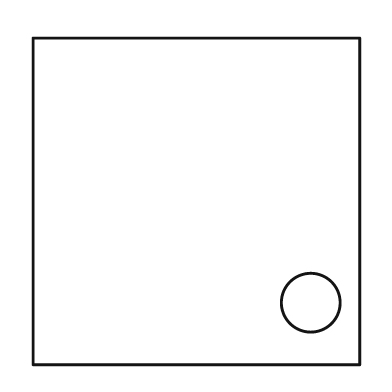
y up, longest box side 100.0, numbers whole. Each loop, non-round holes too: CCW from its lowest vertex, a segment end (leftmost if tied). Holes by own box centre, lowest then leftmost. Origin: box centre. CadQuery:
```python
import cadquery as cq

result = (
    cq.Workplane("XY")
    .moveTo(-50.0, -50.0)
    .lineTo(50.0, -50.0)
    .lineTo(50.0, 50.0)
    .lineTo(-50.0, 50.0)
    .close()
    .moveTo(35.0, -31.0)
    .circle(9.0)
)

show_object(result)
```